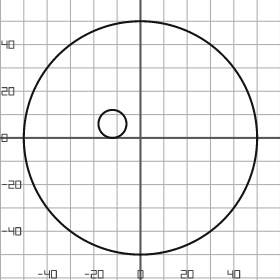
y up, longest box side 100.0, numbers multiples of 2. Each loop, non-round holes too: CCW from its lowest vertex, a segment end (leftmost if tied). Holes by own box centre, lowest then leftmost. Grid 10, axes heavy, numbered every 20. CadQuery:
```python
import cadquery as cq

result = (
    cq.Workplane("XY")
    .moveTo(0.0, 0.0)
    .circle(50.0)
    .moveTo(-12.0, 6.0)
    .circle(6.0)
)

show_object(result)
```